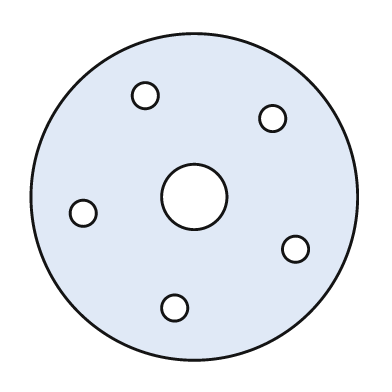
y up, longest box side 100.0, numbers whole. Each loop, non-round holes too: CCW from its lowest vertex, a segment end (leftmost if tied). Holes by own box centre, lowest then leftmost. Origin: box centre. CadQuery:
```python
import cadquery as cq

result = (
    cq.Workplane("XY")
    .moveTo(0.0, 0.0)
    .circle(50.0)
    .moveTo(-6.0, -34.0)
    .circle(4.0)
    .moveTo(31.0, -16.0)
    .circle(4.0)
    .moveTo(-34.0, -5.0)
    .circle(4.0)
    .moveTo(0.0, 0.0)
    .circle(10.0)
    .moveTo(24.0, 24.0)
    .circle(4.0)
    .moveTo(-15.0, 31.0)
    .circle(4.0)
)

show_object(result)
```